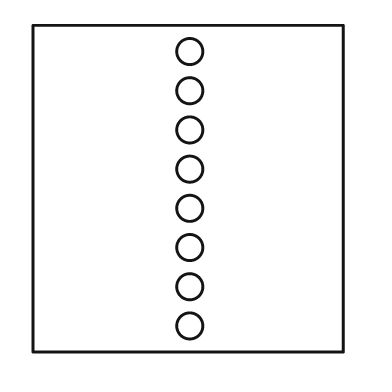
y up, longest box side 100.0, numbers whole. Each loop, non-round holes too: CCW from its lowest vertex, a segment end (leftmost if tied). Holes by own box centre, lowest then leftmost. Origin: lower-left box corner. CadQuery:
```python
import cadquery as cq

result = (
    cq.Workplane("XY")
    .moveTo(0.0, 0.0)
    .lineTo(95.0, 0.0)
    .lineTo(95.0, 100.0)
    .lineTo(0.0, 100.0)
    .close()
    .moveTo(48.0, 8.0)
    .circle(4.0)
    .moveTo(48.0, 20.0)
    .circle(4.0)
    .moveTo(48.0, 32.0)
    .circle(4.0)
    .moveTo(48.0, 44.0)
    .circle(4.0)
    .moveTo(48.0, 56.0)
    .circle(4.0)
    .moveTo(48.0, 68.0)
    .circle(4.0)
    .moveTo(48.0, 80.0)
    .circle(4.0)
    .moveTo(48.0, 92.0)
    .circle(4.0)
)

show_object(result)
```